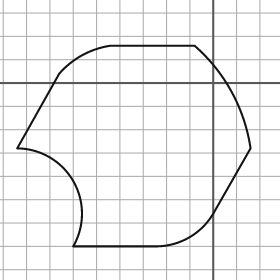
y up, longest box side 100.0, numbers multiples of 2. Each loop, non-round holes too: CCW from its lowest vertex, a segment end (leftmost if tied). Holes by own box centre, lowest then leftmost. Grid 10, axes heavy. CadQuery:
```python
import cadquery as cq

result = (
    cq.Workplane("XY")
    .moveTo(-60.0, -70.0)
    .lineTo(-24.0, -70.0)
    .threePointArc((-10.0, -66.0), (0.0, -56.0))
    .lineTo(16.0, -28.0)
    .threePointArc((8.0, -4.0), (-8.0, 16.0))
    .lineTo(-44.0, 16.0)
    .threePointArc((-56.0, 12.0), (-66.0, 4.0))
    .lineTo(-84.0, -28.0)
    .threePointArc((-60.0, -42.0), (-60.0, -70.0))
    .close()
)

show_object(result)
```